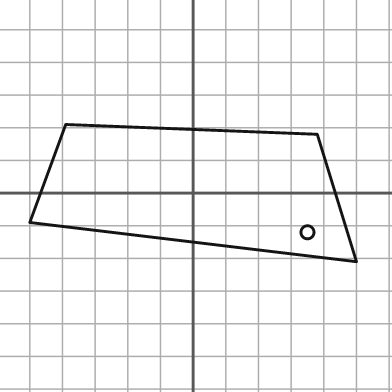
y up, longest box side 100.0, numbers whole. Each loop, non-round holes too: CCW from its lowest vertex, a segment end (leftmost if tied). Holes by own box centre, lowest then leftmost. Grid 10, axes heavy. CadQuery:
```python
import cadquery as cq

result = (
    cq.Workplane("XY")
    .moveTo(50.0, -21.0)
    .lineTo(38.0, 18.0)
    .lineTo(-39.0, 21.0)
    .lineTo(-50.0, -9.0)
    .close()
    .moveTo(35.0, -12.0)
    .circle(2.0)
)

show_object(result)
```